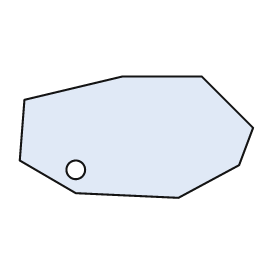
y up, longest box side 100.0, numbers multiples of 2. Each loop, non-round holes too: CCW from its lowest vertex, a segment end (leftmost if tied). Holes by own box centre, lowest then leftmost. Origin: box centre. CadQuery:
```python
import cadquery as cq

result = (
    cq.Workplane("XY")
    .moveTo(18.0, -26.0)
    .lineTo(44.0, -12.0)
    .lineTo(50.0, 4.0)
    .lineTo(28.0, 26.0)
    .lineTo(-6.0, 26.0)
    .lineTo(-48.0, 16.0)
    .lineTo(-50.0, -10.0)
    .lineTo(-26.0, -24.0)
    .close()
    .moveTo(-26.0, -14.0)
    .circle(4.0)
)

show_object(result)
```